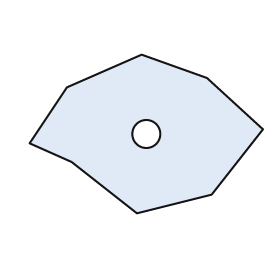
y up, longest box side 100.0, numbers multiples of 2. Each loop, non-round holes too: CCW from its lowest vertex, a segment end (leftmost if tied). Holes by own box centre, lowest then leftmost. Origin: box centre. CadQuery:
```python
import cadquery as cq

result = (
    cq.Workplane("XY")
    .moveTo(-4.0, -34.0)
    .lineTo(28.0, -26.0)
    .lineTo(50.0, 2.0)
    .lineTo(26.0, 24.0)
    .lineTo(-2.0, 34.0)
    .lineTo(-34.0, 20.0)
    .lineTo(-50.0, -4.0)
    .lineTo(-32.0, -12.0)
    .close()
    .moveTo(0.0, 0.0)
    .circle(6.0)
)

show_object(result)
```